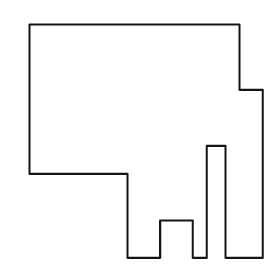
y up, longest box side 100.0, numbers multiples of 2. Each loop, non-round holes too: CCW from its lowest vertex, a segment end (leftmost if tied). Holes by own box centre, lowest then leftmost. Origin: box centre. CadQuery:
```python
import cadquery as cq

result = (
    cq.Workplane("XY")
    .moveTo(-8.0, -50.0)
    .lineTo(6.0, -50.0)
    .lineTo(6.0, -34.0)
    .lineTo(20.0, -34.0)
    .lineTo(20.0, -50.0)
    .lineTo(26.0, -50.0)
    .lineTo(26.0, -2.0)
    .lineTo(34.0, -2.0)
    .lineTo(34.0, -50.0)
    .lineTo(50.0, -50.0)
    .lineTo(50.0, 22.0)
    .lineTo(40.0, 22.0)
    .lineTo(40.0, 50.0)
    .lineTo(-50.0, 50.0)
    .lineTo(-50.0, -14.0)
    .lineTo(-8.0, -14.0)
    .close()
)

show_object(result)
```